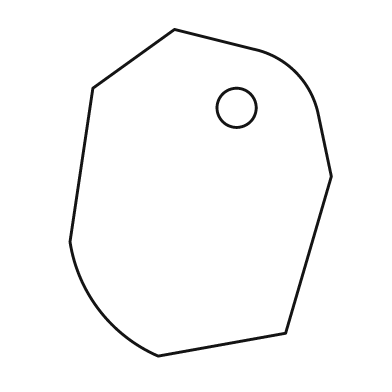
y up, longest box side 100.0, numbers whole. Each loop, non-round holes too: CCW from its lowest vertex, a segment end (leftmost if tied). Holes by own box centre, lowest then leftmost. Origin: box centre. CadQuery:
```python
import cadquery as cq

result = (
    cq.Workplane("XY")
    .moveTo(-13.0, -50.0)
    .lineTo(26.0, -43.0)
    .lineTo(40.0, 5.0)
    .lineTo(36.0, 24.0)
    .threePointArc((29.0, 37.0), (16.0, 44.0))
    .lineTo(-8.0, 50.0)
    .lineTo(-33.0, 32.0)
    .lineTo(-40.0, -15.0)
    .threePointArc((-31.0, -36.0), (-13.0, -50.0))
    .close()
    .moveTo(11.0, 26.0)
    .circle(6.0)
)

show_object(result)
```